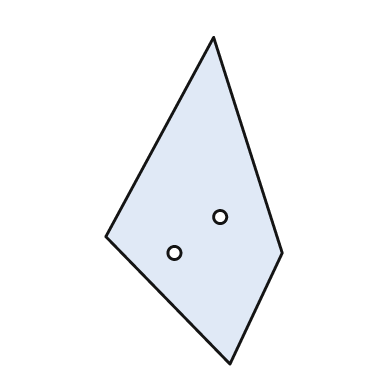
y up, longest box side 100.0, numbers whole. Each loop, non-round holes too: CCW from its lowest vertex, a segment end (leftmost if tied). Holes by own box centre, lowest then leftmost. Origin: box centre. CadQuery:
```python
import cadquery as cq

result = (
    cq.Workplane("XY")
    .moveTo(11.0, -50.0)
    .lineTo(27.0, -16.0)
    .lineTo(6.0, 50.0)
    .lineTo(-27.0, -11.0)
    .close()
    .moveTo(-6.0, -16.0)
    .circle(2.0)
    .moveTo(8.0, -5.0)
    .circle(2.0)
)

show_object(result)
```